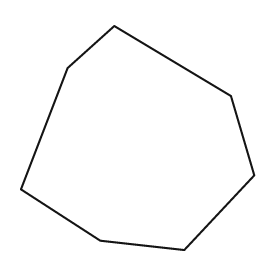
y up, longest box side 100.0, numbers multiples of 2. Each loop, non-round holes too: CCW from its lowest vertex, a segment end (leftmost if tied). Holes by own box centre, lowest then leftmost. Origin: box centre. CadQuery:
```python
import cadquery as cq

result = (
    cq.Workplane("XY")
    .moveTo(20.0, -48.0)
    .lineTo(50.0, -16.0)
    .lineTo(40.0, 18.0)
    .lineTo(-10.0, 48.0)
    .lineTo(-30.0, 30.0)
    .lineTo(-50.0, -22.0)
    .lineTo(-16.0, -44.0)
    .close()
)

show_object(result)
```